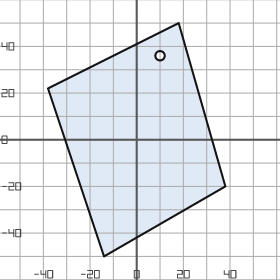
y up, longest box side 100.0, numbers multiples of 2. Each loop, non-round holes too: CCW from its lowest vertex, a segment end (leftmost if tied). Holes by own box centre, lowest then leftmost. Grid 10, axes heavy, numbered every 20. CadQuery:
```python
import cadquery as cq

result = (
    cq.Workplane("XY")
    .moveTo(-14.0, -50.0)
    .lineTo(38.0, -20.0)
    .lineTo(18.0, 50.0)
    .lineTo(-38.0, 22.0)
    .close()
    .moveTo(10.0, 36.0)
    .circle(2.0)
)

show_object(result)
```